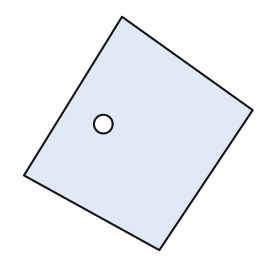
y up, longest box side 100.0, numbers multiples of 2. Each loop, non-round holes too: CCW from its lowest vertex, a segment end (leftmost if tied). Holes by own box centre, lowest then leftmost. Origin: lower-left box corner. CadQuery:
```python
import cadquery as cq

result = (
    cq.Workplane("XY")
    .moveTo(58.0, 0.0)
    .lineTo(98.0, 60.0)
    .lineTo(42.0, 100.0)
    .lineTo(0.0, 32.0)
    .close()
    .moveTo(34.0, 54.0)
    .circle(4.0)
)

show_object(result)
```